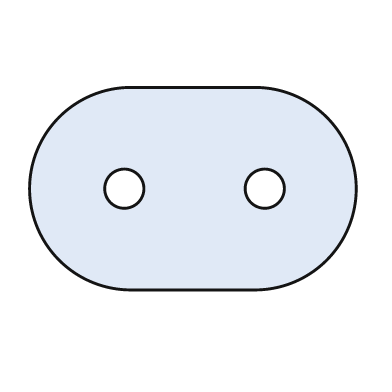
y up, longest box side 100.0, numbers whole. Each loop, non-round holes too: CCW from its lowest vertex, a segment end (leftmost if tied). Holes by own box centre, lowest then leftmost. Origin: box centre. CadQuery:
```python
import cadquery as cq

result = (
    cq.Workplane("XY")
    .moveTo(-19.0, -31.0)
    .lineTo(19.0, -31.0)
    .threePointArc((50.0, 0.0), (19.0, 31.0))
    .lineTo(-19.0, 31.0)
    .threePointArc((-50.0, 0.0), (-19.0, -31.0))
    .close()
    .moveTo(-21.0, 0.0)
    .circle(6.0)
    .moveTo(22.0, 0.0)
    .circle(6.0)
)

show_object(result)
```